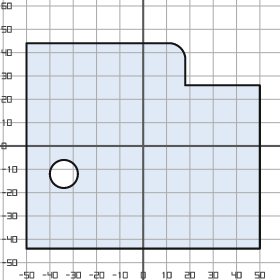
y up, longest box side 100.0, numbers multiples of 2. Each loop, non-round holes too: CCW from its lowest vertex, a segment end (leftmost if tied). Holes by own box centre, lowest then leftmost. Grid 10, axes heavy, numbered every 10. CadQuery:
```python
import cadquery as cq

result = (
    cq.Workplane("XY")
    .moveTo(-50.0, -44.0)
    .lineTo(50.0, -44.0)
    .lineTo(50.0, 26.0)
    .lineTo(18.0, 26.0)
    .lineTo(18.0, 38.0)
    .threePointArc((16.0, 42.0), (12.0, 44.0))
    .lineTo(-50.0, 44.0)
    .close()
    .moveTo(-34.0, -12.0)
    .circle(6.0)
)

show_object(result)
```